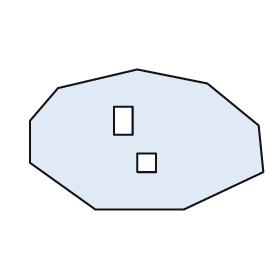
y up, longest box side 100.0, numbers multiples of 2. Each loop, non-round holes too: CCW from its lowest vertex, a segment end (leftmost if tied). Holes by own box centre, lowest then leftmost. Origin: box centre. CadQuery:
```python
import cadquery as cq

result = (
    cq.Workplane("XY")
    .moveTo(-22.0, -30.0)
    .lineTo(16.0, -30.0)
    .lineTo(50.0, -14.0)
    .lineTo(48.0, 6.0)
    .lineTo(26.0, 24.0)
    .lineTo(-4.0, 30.0)
    .lineTo(-38.0, 22.0)
    .lineTo(-50.0, 8.0)
    .lineTo(-50.0, -10.0)
    .close()
    .moveTo(-4.0, -14.0)
    .lineTo(4.0, -14.0)
    .lineTo(4.0, -6.0)
    .lineTo(-4.0, -6.0)
    .close()
    .moveTo(-14.0, 2.0)
    .lineTo(-6.0, 2.0)
    .lineTo(-6.0, 14.0)
    .lineTo(-14.0, 14.0)
    .close()
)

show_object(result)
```